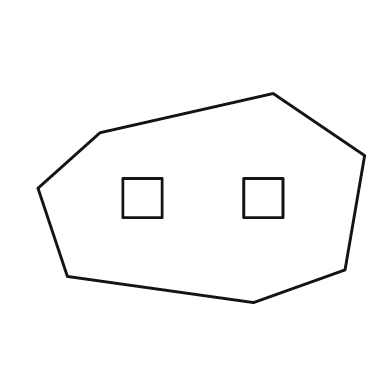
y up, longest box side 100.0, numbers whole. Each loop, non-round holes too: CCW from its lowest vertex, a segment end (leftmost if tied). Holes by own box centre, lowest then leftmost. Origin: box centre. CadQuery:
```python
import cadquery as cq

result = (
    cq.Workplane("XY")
    .moveTo(16.0, -32.0)
    .lineTo(44.0, -22.0)
    .lineTo(50.0, 13.0)
    .lineTo(22.0, 32.0)
    .lineTo(-31.0, 20.0)
    .lineTo(-50.0, 3.0)
    .lineTo(-41.0, -24.0)
    .close()
    .moveTo(-24.0, -6.0)
    .lineTo(-12.0, -6.0)
    .lineTo(-12.0, 6.0)
    .lineTo(-24.0, 6.0)
    .close()
    .moveTo(13.0, -6.0)
    .lineTo(25.0, -6.0)
    .lineTo(25.0, 6.0)
    .lineTo(13.0, 6.0)
    .close()
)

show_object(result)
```